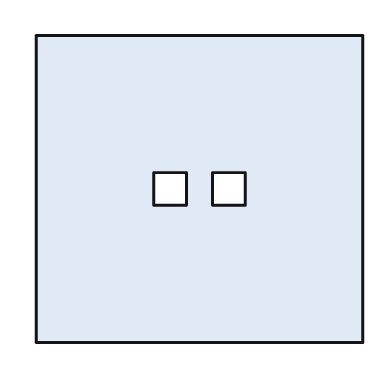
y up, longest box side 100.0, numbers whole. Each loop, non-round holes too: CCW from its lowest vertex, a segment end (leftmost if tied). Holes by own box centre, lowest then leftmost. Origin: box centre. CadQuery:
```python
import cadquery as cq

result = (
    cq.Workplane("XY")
    .moveTo(-50.0, -47.0)
    .lineTo(50.0, -47.0)
    .lineTo(50.0, 47.0)
    .lineTo(-50.0, 47.0)
    .close()
    .moveTo(-14.0, -5.0)
    .lineTo(-4.0, -5.0)
    .lineTo(-4.0, 5.0)
    .lineTo(-14.0, 5.0)
    .close()
    .moveTo(4.0, -5.0)
    .lineTo(14.0, -5.0)
    .lineTo(14.0, 5.0)
    .lineTo(4.0, 5.0)
    .close()
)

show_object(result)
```